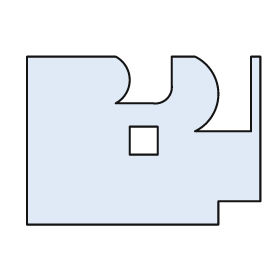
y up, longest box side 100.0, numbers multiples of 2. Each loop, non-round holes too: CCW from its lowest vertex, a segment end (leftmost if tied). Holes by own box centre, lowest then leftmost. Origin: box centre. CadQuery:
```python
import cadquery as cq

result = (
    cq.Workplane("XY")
    .moveTo(-50.0, -36.0)
    .lineTo(32.0, -36.0)
    .lineTo(32.0, -26.0)
    .lineTo(50.0, -26.0)
    .lineTo(50.0, 36.0)
    .lineTo(46.0, 36.0)
    .lineTo(46.0, 4.0)
    .lineTo(22.0, 4.0)
    .threePointArc((32.0, 20.0), (22.0, 36.0))
    .lineTo(12.0, 36.0)
    .lineTo(12.0, 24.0)
    .threePointArc((10.0, 18.0), (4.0, 16.0))
    .lineTo(-12.0, 16.0)
    .threePointArc((-6.0, 26.0), (-12.0, 36.0))
    .lineTo(-50.0, 36.0)
    .close()
    .moveTo(-6.0, -6.0)
    .lineTo(6.0, -6.0)
    .lineTo(6.0, 6.0)
    .lineTo(-6.0, 6.0)
    .close()
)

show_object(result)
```